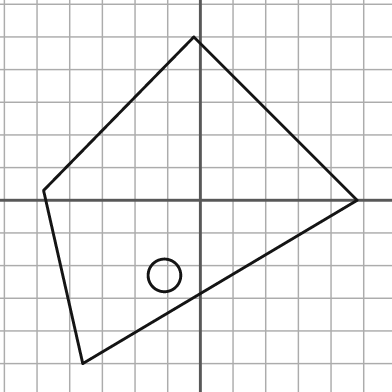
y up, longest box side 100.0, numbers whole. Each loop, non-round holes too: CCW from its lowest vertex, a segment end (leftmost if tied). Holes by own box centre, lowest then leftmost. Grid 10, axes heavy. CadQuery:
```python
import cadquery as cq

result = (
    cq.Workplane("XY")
    .moveTo(-36.0, -50.0)
    .lineTo(48.0, 0.0)
    .lineTo(-2.0, 50.0)
    .lineTo(-48.0, 3.0)
    .close()
    .moveTo(-11.0, -23.0)
    .circle(5.0)
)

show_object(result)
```